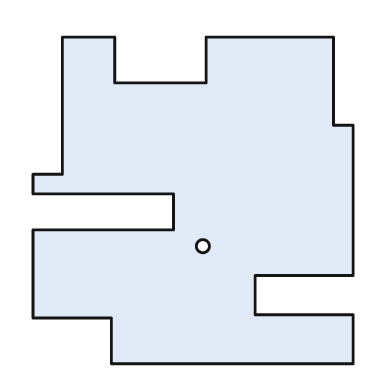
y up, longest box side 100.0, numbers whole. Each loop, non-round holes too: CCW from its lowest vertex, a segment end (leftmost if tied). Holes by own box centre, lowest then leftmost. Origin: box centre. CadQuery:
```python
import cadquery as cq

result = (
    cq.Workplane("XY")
    .moveTo(-25.0, -50.0)
    .lineTo(49.0, -50.0)
    .lineTo(49.0, -35.0)
    .lineTo(19.0, -35.0)
    .lineTo(19.0, -23.0)
    .lineTo(49.0, -23.0)
    .lineTo(49.0, 23.0)
    .lineTo(43.0, 23.0)
    .lineTo(43.0, 50.0)
    .lineTo(4.0, 50.0)
    .lineTo(4.0, 36.0)
    .lineTo(-24.0, 36.0)
    .lineTo(-24.0, 50.0)
    .lineTo(-40.0, 50.0)
    .lineTo(-40.0, 8.0)
    .lineTo(-49.0, 8.0)
    .lineTo(-49.0, 2.0)
    .lineTo(-6.0, 2.0)
    .lineTo(-6.0, -9.0)
    .lineTo(-49.0, -9.0)
    .lineTo(-49.0, -36.0)
    .lineTo(-25.0, -36.0)
    .close()
    .moveTo(3.0, -14.0)
    .circle(2.0)
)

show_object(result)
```